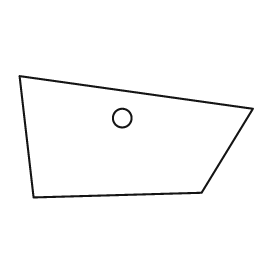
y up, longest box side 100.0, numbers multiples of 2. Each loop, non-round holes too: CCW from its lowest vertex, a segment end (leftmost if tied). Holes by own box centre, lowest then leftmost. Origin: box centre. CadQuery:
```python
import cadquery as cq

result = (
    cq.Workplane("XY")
    .moveTo(-44.0, -26.0)
    .lineTo(28.0, -24.0)
    .lineTo(50.0, 12.0)
    .lineTo(-50.0, 26.0)
    .close()
    .moveTo(-6.0, 8.0)
    .circle(4.0)
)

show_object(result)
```